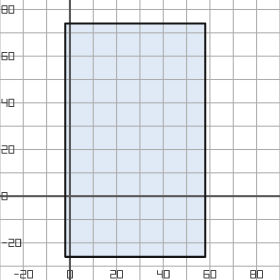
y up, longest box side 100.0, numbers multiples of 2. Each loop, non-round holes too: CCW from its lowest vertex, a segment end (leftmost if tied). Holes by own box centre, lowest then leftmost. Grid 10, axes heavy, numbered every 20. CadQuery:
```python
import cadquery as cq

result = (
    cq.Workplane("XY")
    .moveTo(-2.0, -26.0)
    .lineTo(58.0, -26.0)
    .lineTo(58.0, 74.0)
    .lineTo(-2.0, 74.0)
    .close()
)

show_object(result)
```